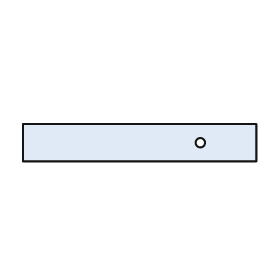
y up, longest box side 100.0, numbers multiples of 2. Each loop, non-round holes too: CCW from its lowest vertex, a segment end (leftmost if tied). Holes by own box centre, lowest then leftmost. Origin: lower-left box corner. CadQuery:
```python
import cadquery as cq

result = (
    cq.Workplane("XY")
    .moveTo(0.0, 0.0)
    .lineTo(100.0, 0.0)
    .lineTo(100.0, 16.0)
    .lineTo(0.0, 16.0)
    .close()
    .moveTo(76.0, 8.0)
    .circle(2.0)
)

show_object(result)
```